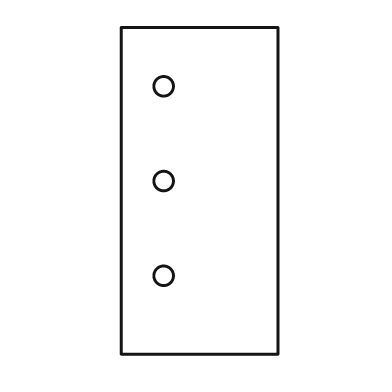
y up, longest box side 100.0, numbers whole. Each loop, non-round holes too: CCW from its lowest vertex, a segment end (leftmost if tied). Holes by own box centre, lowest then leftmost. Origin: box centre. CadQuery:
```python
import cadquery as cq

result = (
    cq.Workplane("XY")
    .moveTo(-24.0, -50.0)
    .lineTo(24.0, -50.0)
    .lineTo(24.0, 50.0)
    .lineTo(-24.0, 50.0)
    .close()
    .moveTo(-11.0, -26.0)
    .circle(3.0)
    .moveTo(-11.0, 3.0)
    .circle(3.0)
    .moveTo(-11.0, 32.0)
    .circle(3.0)
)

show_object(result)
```